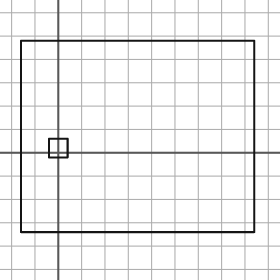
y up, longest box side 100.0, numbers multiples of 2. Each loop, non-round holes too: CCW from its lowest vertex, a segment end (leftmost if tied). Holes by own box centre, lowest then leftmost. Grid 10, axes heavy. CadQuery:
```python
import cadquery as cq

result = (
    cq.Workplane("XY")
    .moveTo(-16.0, -34.0)
    .lineTo(84.0, -34.0)
    .lineTo(84.0, 48.0)
    .lineTo(-16.0, 48.0)
    .close()
    .moveTo(-4.0, -2.0)
    .lineTo(4.0, -2.0)
    .lineTo(4.0, 6.0)
    .lineTo(-4.0, 6.0)
    .close()
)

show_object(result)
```